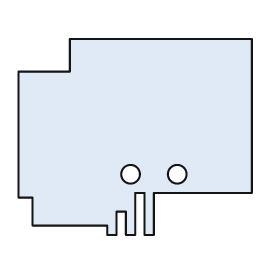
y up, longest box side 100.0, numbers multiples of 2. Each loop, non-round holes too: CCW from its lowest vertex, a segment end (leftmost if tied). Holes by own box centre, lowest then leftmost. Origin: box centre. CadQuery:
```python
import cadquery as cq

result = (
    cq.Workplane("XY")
    .moveTo(-12.0, -42.0)
    .lineTo(-8.0, -42.0)
    .lineTo(-8.0, -32.0)
    .lineTo(-4.0, -32.0)
    .lineTo(-4.0, -42.0)
    .lineTo(0.0, -42.0)
    .lineTo(0.0, -24.0)
    .lineTo(4.0, -24.0)
    .lineTo(4.0, -42.0)
    .lineTo(8.0, -42.0)
    .lineTo(8.0, -24.0)
    .lineTo(50.0, -24.0)
    .lineTo(50.0, 42.0)
    .lineTo(-28.0, 42.0)
    .lineTo(-28.0, 28.0)
    .lineTo(-50.0, 28.0)
    .lineTo(-50.0, -26.0)
    .lineTo(-44.0, -26.0)
    .lineTo(-44.0, -38.0)
    .lineTo(-12.0, -38.0)
    .close()
    .moveTo(-2.0, -16.0)
    .circle(4.0)
    .moveTo(18.0, -16.0)
    .circle(4.0)
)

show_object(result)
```